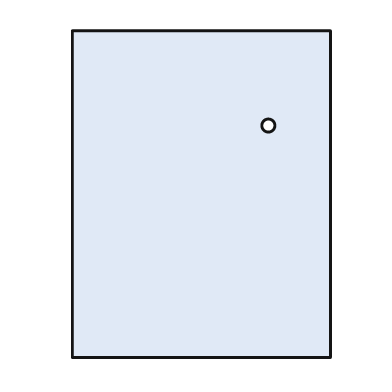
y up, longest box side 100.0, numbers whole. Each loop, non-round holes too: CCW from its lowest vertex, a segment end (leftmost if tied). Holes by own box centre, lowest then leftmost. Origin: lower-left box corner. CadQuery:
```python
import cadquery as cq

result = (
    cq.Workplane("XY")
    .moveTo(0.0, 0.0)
    .lineTo(79.0, 0.0)
    .lineTo(79.0, 100.0)
    .lineTo(0.0, 100.0)
    .close()
    .moveTo(60.0, 71.0)
    .circle(2.0)
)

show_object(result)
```